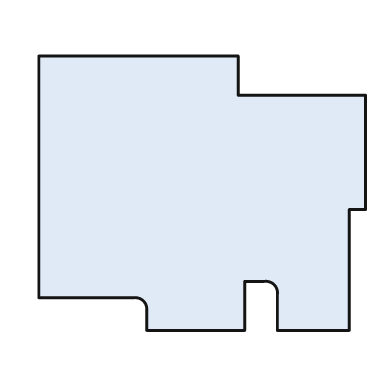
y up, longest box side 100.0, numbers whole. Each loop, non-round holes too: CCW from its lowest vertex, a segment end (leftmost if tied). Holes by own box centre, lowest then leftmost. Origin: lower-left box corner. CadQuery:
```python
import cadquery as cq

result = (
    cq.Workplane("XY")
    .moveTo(33.0, 0.0)
    .lineTo(63.0, 0.0)
    .lineTo(63.0, 15.0)
    .lineTo(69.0, 15.0)
    .threePointArc((72.0, 14.0), (73.0, 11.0))
    .lineTo(73.0, 0.0)
    .lineTo(95.0, 0.0)
    .lineTo(95.0, 37.0)
    .lineTo(100.0, 37.0)
    .lineTo(100.0, 72.0)
    .lineTo(61.0, 72.0)
    .lineTo(61.0, 84.0)
    .lineTo(0.0, 84.0)
    .lineTo(0.0, 10.0)
    .lineTo(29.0, 10.0)
    .threePointArc((32.0, 9.0), (33.0, 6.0))
    .close()
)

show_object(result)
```